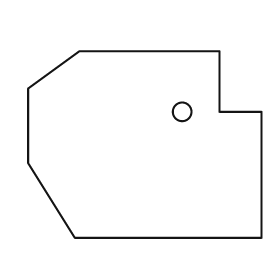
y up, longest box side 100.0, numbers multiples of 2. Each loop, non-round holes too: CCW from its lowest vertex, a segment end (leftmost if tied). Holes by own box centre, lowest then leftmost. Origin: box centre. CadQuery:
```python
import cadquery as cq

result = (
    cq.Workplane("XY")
    .moveTo(-30.0, -40.0)
    .lineTo(50.0, -40.0)
    .lineTo(50.0, 14.0)
    .lineTo(32.0, 14.0)
    .lineTo(32.0, 40.0)
    .lineTo(-28.0, 40.0)
    .lineTo(-50.0, 24.0)
    .lineTo(-50.0, -8.0)
    .close()
    .moveTo(16.0, 14.0)
    .circle(4.0)
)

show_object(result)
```